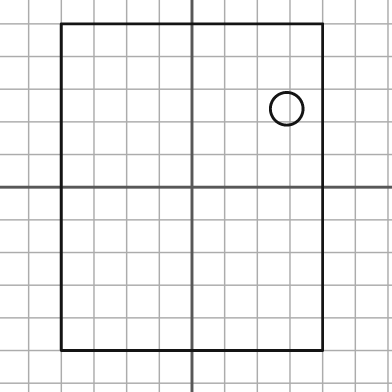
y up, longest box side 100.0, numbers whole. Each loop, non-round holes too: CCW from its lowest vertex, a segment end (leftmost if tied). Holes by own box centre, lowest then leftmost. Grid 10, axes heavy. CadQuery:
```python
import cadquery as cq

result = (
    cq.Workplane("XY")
    .moveTo(-40.0, -50.0)
    .lineTo(40.0, -50.0)
    .lineTo(40.0, 50.0)
    .lineTo(-40.0, 50.0)
    .close()
    .moveTo(29.0, 24.0)
    .circle(5.0)
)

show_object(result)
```